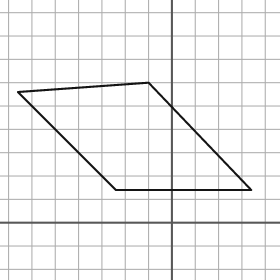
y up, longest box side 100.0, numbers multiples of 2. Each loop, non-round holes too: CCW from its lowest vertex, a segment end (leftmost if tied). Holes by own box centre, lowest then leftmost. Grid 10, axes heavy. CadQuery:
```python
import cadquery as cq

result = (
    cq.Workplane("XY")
    .moveTo(-24.0, 14.0)
    .lineTo(34.0, 14.0)
    .lineTo(-10.0, 60.0)
    .lineTo(-66.0, 56.0)
    .close()
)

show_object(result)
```